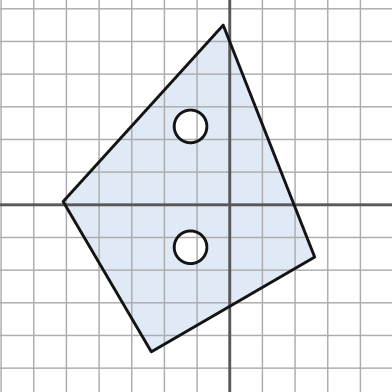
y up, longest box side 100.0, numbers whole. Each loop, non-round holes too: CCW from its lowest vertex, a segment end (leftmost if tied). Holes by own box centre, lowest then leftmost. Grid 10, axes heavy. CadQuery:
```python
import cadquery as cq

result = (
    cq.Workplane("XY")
    .moveTo(-24.0, -45.0)
    .lineTo(26.0, -16.0)
    .lineTo(-2.0, 55.0)
    .lineTo(-51.0, 1.0)
    .close()
    .moveTo(-12.0, -13.0)
    .circle(5.0)
    .moveTo(-12.0, 24.0)
    .circle(5.0)
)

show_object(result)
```